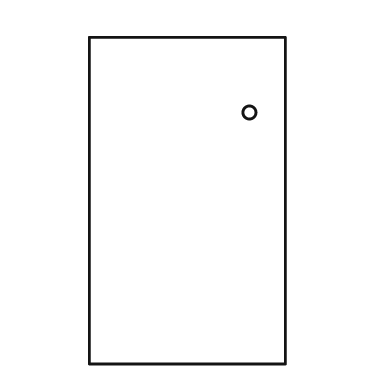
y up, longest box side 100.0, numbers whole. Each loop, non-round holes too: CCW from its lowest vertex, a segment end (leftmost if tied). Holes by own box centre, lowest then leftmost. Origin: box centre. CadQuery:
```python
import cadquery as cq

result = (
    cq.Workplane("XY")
    .moveTo(-30.0, -50.0)
    .lineTo(30.0, -50.0)
    .lineTo(30.0, 50.0)
    .lineTo(-30.0, 50.0)
    .close()
    .moveTo(19.0, 27.0)
    .circle(2.0)
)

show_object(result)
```